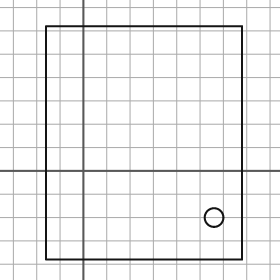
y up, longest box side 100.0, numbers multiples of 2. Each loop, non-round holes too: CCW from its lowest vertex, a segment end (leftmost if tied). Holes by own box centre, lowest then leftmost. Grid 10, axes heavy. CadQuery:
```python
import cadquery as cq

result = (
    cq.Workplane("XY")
    .moveTo(-16.0, -38.0)
    .lineTo(68.0, -38.0)
    .lineTo(68.0, 62.0)
    .lineTo(-16.0, 62.0)
    .close()
    .moveTo(56.0, -20.0)
    .circle(4.0)
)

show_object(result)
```